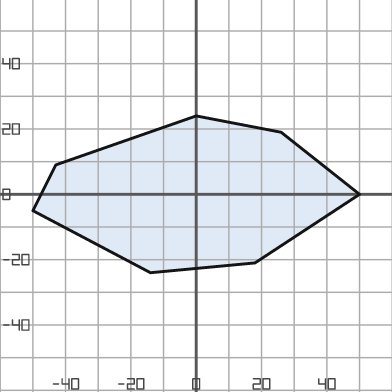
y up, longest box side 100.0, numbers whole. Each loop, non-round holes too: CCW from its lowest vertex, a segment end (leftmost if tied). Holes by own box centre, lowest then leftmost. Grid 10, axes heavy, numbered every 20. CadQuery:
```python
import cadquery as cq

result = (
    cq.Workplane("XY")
    .moveTo(-14.0, -24.0)
    .lineTo(18.0, -21.0)
    .lineTo(50.0, 0.0)
    .lineTo(26.0, 19.0)
    .lineTo(0.0, 24.0)
    .lineTo(-43.0, 9.0)
    .lineTo(-50.0, -5.0)
    .close()
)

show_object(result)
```